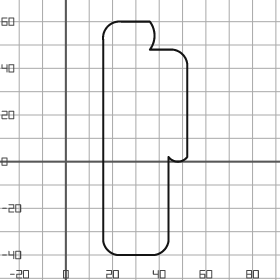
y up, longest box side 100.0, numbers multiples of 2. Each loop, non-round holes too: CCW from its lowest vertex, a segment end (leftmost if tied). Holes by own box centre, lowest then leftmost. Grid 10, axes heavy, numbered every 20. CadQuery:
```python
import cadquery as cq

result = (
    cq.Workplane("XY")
    .moveTo(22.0, -40.0)
    .lineTo(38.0, -40.0)
    .threePointArc((42.0, -38.0), (44.0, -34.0))
    .lineTo(44.0, 2.0)
    .threePointArc((48.0, 0.0), (52.0, 2.0))
    .lineTo(52.0, 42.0)
    .threePointArc((50.0, 46.0), (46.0, 48.0))
    .lineTo(36.0, 48.0)
    .threePointArc((38.0, 54.0), (36.0, 60.0))
    .lineTo(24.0, 60.0)
    .threePointArc((18.0, 58.0), (16.0, 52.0))
    .lineTo(16.0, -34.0)
    .threePointArc((18.0, -38.0), (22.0, -40.0))
    .close()
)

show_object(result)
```